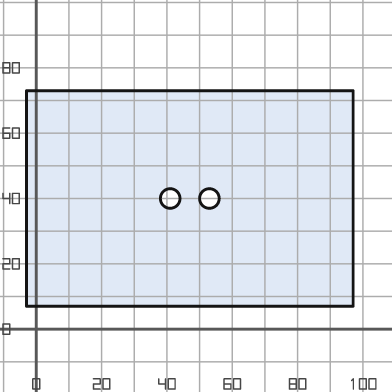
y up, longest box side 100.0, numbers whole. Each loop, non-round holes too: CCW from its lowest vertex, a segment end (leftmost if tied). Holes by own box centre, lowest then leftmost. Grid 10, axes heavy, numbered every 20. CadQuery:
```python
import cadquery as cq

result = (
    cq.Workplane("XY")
    .moveTo(-3.0, 7.0)
    .lineTo(97.0, 7.0)
    .lineTo(97.0, 73.0)
    .lineTo(-3.0, 73.0)
    .close()
    .moveTo(41.0, 40.0)
    .circle(3.0)
    .moveTo(53.0, 40.0)
    .circle(3.0)
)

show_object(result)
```